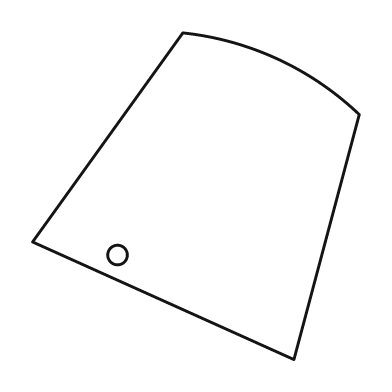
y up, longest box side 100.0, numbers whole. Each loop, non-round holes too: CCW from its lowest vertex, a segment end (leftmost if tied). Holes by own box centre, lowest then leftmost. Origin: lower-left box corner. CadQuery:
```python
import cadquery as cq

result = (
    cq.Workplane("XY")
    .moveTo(80.0, 0.0)
    .lineTo(100.0, 75.0)
    .threePointArc((75.0, 92.0), (46.0, 100.0))
    .lineTo(0.0, 36.0)
    .close()
    .moveTo(26.0, 32.0)
    .circle(3.0)
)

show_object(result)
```